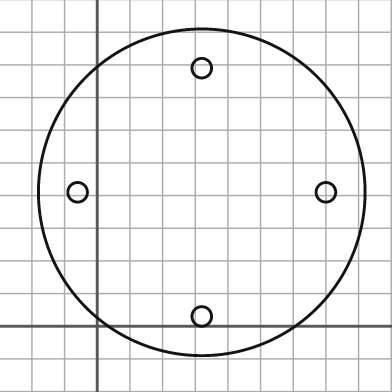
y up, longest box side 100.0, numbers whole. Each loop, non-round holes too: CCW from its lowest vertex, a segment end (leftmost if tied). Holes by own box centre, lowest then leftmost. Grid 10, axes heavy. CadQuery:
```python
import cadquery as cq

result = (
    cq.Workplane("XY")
    .moveTo(32.0, 41.0)
    .circle(50.0)
    .moveTo(32.0, 3.0)
    .circle(3.0)
    .moveTo(-6.0, 41.0)
    .circle(3.0)
    .moveTo(70.0, 41.0)
    .circle(3.0)
    .moveTo(32.0, 79.0)
    .circle(3.0)
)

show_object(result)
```